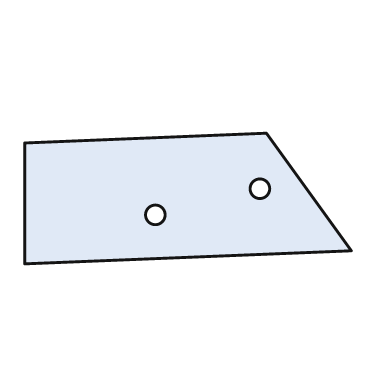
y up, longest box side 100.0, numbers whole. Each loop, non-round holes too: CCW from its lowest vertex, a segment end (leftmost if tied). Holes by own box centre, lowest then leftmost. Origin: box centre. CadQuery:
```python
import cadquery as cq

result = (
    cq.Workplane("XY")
    .moveTo(-50.0, -20.0)
    .lineTo(50.0, -16.0)
    .lineTo(24.0, 20.0)
    .lineTo(-50.0, 17.0)
    .close()
    .moveTo(-10.0, -5.0)
    .circle(3.0)
    .moveTo(22.0, 3.0)
    .circle(3.0)
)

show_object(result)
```